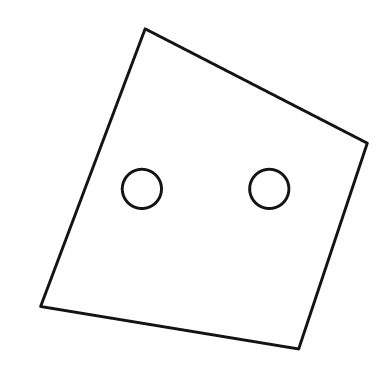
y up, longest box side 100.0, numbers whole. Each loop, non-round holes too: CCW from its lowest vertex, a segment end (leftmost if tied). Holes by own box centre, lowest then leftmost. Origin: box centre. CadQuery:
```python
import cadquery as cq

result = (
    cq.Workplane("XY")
    .moveTo(29.0, -49.0)
    .lineTo(50.0, 14.0)
    .lineTo(-18.0, 49.0)
    .lineTo(-50.0, -36.0)
    .close()
    .moveTo(-19.0, 0.0)
    .circle(6.0)
    .moveTo(20.0, 0.0)
    .circle(6.0)
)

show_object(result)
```